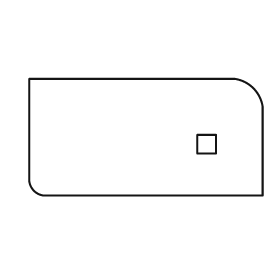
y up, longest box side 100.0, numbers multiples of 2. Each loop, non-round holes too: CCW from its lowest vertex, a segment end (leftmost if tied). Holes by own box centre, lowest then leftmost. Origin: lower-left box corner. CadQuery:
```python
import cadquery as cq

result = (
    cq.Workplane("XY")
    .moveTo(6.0, 0.0)
    .lineTo(100.0, 0.0)
    .lineTo(100.0, 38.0)
    .threePointArc((96.0, 46.0), (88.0, 50.0))
    .lineTo(0.0, 50.0)
    .lineTo(0.0, 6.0)
    .threePointArc((2.0, 2.0), (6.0, 0.0))
    .close()
    .moveTo(72.0, 18.0)
    .lineTo(80.0, 18.0)
    .lineTo(80.0, 26.0)
    .lineTo(72.0, 26.0)
    .close()
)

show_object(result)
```